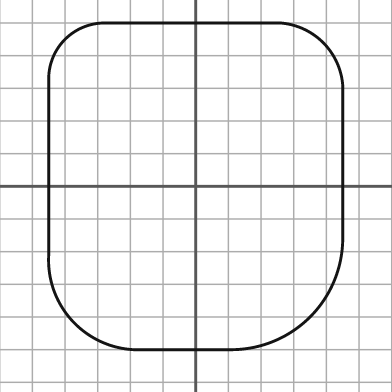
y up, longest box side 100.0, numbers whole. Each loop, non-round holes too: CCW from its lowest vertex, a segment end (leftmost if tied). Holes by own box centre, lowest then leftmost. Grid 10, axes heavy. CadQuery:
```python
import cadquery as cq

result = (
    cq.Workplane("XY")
    .moveTo(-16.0, -50.0)
    .lineTo(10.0, -50.0)
    .threePointArc((35.0, -40.0), (45.0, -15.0))
    .lineTo(45.0, 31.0)
    .threePointArc((39.0, 44.0), (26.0, 50.0))
    .lineTo(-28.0, 50.0)
    .threePointArc((-40.0, 45.0), (-45.0, 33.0))
    .lineTo(-45.0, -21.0)
    .threePointArc((-37.0, -42.0), (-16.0, -50.0))
    .close()
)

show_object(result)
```